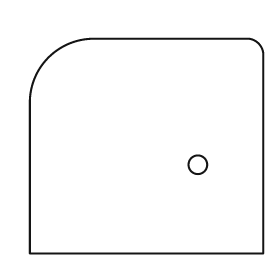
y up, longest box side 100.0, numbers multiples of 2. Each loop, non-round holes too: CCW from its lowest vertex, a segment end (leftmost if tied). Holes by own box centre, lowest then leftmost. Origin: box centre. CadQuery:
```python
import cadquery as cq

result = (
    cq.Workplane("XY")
    .moveTo(-50.0, -46.0)
    .lineTo(50.0, -46.0)
    .lineTo(50.0, 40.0)
    .threePointArc((48.0, 44.0), (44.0, 46.0))
    .lineTo(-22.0, 46.0)
    .threePointArc((-42.0, 38.0), (-50.0, 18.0))
    .close()
    .moveTo(22.0, -8.0)
    .circle(4.0)
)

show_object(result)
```